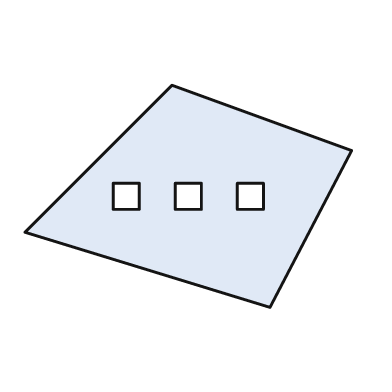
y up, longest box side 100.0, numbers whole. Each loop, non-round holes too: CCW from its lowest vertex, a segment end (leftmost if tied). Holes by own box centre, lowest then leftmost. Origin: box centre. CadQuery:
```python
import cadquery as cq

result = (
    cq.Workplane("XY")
    .moveTo(25.0, -34.0)
    .lineTo(50.0, 14.0)
    .lineTo(-5.0, 34.0)
    .lineTo(-50.0, -11.0)
    .close()
    .moveTo(-23.0, -4.0)
    .lineTo(-15.0, -4.0)
    .lineTo(-15.0, 4.0)
    .lineTo(-23.0, 4.0)
    .close()
    .moveTo(-4.0, -4.0)
    .lineTo(4.0, -4.0)
    .lineTo(4.0, 4.0)
    .lineTo(-4.0, 4.0)
    .close()
    .moveTo(15.0, -4.0)
    .lineTo(23.0, -4.0)
    .lineTo(23.0, 4.0)
    .lineTo(15.0, 4.0)
    .close()
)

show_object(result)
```